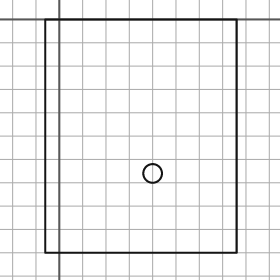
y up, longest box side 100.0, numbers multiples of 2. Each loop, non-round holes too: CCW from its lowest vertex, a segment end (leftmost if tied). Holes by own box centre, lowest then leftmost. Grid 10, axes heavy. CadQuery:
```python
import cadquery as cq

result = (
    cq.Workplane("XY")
    .moveTo(-6.0, -100.0)
    .lineTo(76.0, -100.0)
    .lineTo(76.0, 0.0)
    .lineTo(-6.0, 0.0)
    .close()
    .moveTo(40.0, -66.0)
    .circle(4.0)
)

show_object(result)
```